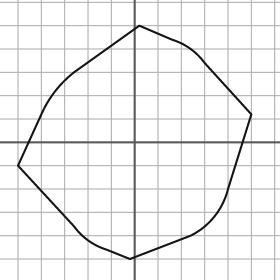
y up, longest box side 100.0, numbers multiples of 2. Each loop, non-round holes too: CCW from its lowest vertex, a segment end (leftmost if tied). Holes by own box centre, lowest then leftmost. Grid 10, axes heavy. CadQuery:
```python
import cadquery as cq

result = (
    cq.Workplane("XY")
    .moveTo(-2.0, -50.0)
    .lineTo(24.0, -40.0)
    .threePointArc((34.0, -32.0), (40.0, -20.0))
    .lineTo(50.0, 12.0)
    .lineTo(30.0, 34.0)
    .threePointArc((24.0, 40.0), (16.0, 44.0))
    .lineTo(2.0, 50.0)
    .lineTo(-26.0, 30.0)
    .threePointArc((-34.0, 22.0), (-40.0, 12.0))
    .lineTo(-50.0, -10.0)
    .lineTo(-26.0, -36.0)
    .threePointArc((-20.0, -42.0), (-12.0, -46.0))
    .close()
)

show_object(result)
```